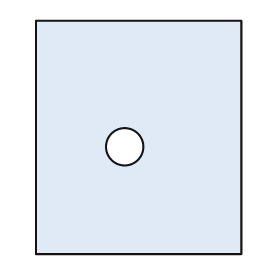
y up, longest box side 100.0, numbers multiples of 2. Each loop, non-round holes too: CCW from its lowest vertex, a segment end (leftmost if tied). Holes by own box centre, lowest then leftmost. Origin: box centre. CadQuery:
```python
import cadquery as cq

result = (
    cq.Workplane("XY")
    .moveTo(-44.0, -50.0)
    .lineTo(44.0, -50.0)
    .lineTo(44.0, 50.0)
    .lineTo(-44.0, 50.0)
    .close()
    .moveTo(-6.0, -4.0)
    .circle(8.0)
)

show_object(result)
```